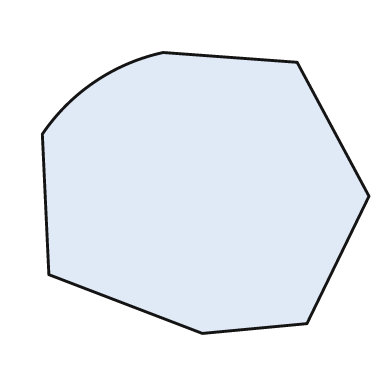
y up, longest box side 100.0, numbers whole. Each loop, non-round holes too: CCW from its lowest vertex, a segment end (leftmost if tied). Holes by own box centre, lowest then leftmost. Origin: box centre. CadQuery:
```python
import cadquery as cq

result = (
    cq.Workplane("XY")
    .moveTo(-1.0, -43.0)
    .lineTo(31.0, -40.0)
    .lineTo(50.0, -1.0)
    .lineTo(28.0, 40.0)
    .lineTo(-13.0, 43.0)
    .threePointArc((-34.0, 34.0), (-50.0, 18.0))
    .lineTo(-48.0, -25.0)
    .close()
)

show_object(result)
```